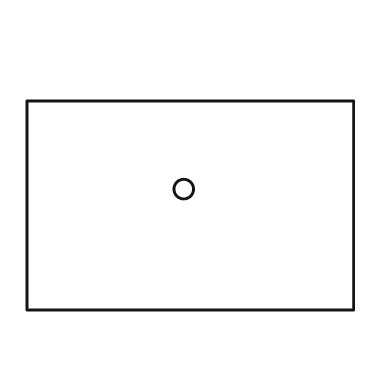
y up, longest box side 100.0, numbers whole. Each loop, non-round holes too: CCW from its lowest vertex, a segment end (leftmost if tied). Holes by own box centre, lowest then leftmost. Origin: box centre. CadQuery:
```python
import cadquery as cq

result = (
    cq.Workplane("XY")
    .moveTo(-50.0, -32.0)
    .lineTo(50.0, -32.0)
    .lineTo(50.0, 32.0)
    .lineTo(-50.0, 32.0)
    .close()
    .moveTo(-2.0, 5.0)
    .circle(3.0)
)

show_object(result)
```